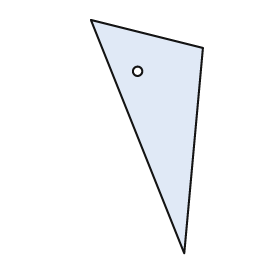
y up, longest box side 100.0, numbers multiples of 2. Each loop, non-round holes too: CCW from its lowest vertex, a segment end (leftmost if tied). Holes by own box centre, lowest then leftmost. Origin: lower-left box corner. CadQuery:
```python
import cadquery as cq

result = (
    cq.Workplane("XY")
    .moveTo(40.0, 0.0)
    .lineTo(48.0, 88.0)
    .lineTo(0.0, 100.0)
    .close()
    .moveTo(20.0, 78.0)
    .circle(2.0)
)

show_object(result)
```